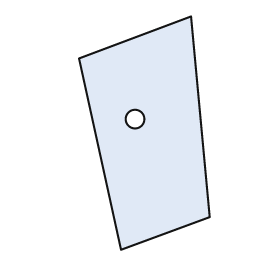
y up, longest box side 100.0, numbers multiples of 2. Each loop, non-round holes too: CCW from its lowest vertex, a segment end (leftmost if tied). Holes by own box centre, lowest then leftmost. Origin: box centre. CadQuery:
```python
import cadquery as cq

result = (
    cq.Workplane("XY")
    .moveTo(-10.0, -50.0)
    .lineTo(28.0, -36.0)
    .lineTo(20.0, 50.0)
    .lineTo(-28.0, 32.0)
    .close()
    .moveTo(-4.0, 6.0)
    .circle(4.0)
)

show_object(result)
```